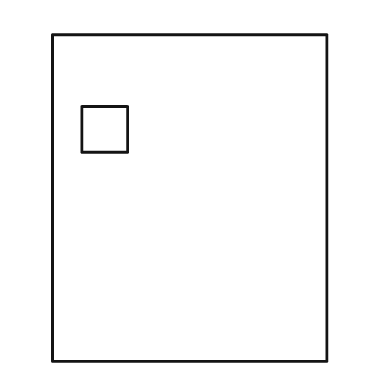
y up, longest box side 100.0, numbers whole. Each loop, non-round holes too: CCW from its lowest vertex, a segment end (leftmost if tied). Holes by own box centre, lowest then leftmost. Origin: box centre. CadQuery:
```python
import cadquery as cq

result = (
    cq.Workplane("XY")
    .moveTo(-42.0, -50.0)
    .lineTo(42.0, -50.0)
    .lineTo(42.0, 50.0)
    .lineTo(-42.0, 50.0)
    .close()
    .moveTo(-33.0, 14.0)
    .lineTo(-19.0, 14.0)
    .lineTo(-19.0, 28.0)
    .lineTo(-33.0, 28.0)
    .close()
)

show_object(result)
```